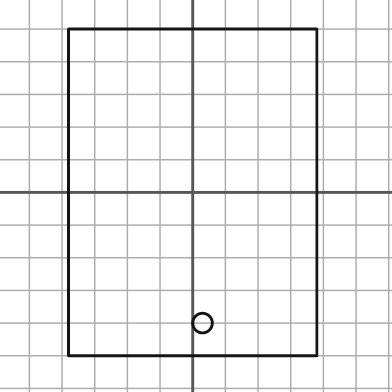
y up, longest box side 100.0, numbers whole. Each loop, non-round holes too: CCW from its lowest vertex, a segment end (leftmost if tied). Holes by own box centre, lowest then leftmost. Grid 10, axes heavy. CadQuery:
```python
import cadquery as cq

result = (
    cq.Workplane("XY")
    .moveTo(-38.0, -50.0)
    .lineTo(38.0, -50.0)
    .lineTo(38.0, 50.0)
    .lineTo(-38.0, 50.0)
    .close()
    .moveTo(3.0, -40.0)
    .circle(3.0)
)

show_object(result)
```